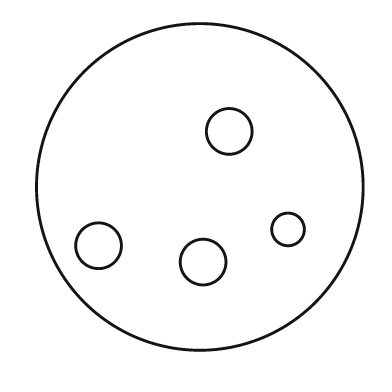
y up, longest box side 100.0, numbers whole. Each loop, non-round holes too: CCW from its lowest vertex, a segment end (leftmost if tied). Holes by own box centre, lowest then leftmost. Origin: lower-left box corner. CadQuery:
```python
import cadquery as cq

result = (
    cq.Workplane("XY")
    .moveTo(50.0, 50.0)
    .circle(50.0)
    .moveTo(51.0, 27.0)
    .circle(7.0)
    .moveTo(19.0, 32.0)
    .circle(7.0)
    .moveTo(77.0, 37.0)
    .circle(5.0)
    .moveTo(59.0, 67.0)
    .circle(7.0)
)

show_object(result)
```